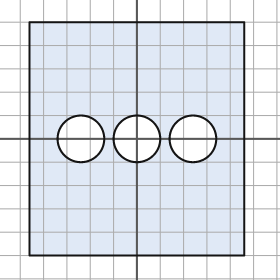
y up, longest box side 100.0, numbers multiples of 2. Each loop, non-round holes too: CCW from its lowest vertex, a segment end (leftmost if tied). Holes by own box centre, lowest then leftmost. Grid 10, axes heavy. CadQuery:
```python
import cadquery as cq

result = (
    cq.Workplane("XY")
    .moveTo(-46.0, -50.0)
    .lineTo(46.0, -50.0)
    .lineTo(46.0, 50.0)
    .lineTo(-46.0, 50.0)
    .close()
    .moveTo(-24.0, 0.0)
    .circle(10.0)
    .moveTo(0.0, 0.0)
    .circle(10.0)
    .moveTo(24.0, 0.0)
    .circle(10.0)
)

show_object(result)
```